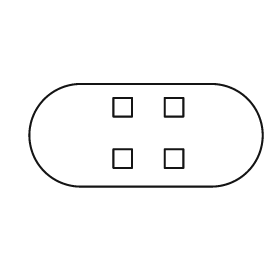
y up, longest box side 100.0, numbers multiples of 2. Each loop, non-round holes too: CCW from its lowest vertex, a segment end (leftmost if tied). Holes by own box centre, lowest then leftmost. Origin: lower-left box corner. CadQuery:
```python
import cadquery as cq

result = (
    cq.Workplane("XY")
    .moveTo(22.0, 0.0)
    .lineTo(78.0, 0.0)
    .threePointArc((100.0, 22.0), (78.0, 44.0))
    .lineTo(22.0, 44.0)
    .threePointArc((0.0, 22.0), (22.0, 0.0))
    .close()
    .moveTo(36.0, 8.0)
    .lineTo(44.0, 8.0)
    .lineTo(44.0, 16.0)
    .lineTo(36.0, 16.0)
    .close()
    .moveTo(58.0, 8.0)
    .lineTo(66.0, 8.0)
    .lineTo(66.0, 16.0)
    .lineTo(58.0, 16.0)
    .close()
    .moveTo(36.0, 30.0)
    .lineTo(44.0, 30.0)
    .lineTo(44.0, 38.0)
    .lineTo(36.0, 38.0)
    .close()
    .moveTo(58.0, 30.0)
    .lineTo(66.0, 30.0)
    .lineTo(66.0, 38.0)
    .lineTo(58.0, 38.0)
    .close()
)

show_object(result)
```